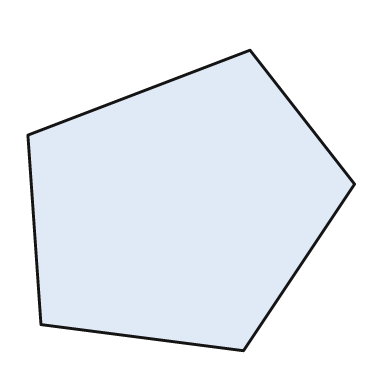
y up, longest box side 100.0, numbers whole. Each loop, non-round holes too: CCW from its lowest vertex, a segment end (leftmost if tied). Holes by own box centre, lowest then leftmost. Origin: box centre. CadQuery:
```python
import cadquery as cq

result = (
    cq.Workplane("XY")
    .moveTo(16.0, -46.0)
    .lineTo(50.0, 5.0)
    .lineTo(18.0, 46.0)
    .lineTo(-50.0, 20.0)
    .lineTo(-46.0, -38.0)
    .close()
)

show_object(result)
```